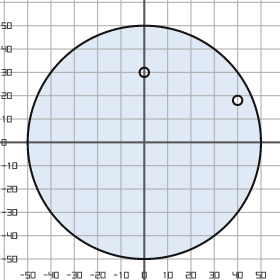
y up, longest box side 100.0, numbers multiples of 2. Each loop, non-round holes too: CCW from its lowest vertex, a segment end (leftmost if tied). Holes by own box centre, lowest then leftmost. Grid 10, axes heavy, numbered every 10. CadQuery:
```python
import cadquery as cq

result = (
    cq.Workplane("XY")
    .moveTo(0.0, 0.0)
    .circle(50.0)
    .moveTo(40.0, 18.0)
    .circle(2.0)
    .moveTo(0.0, 30.0)
    .circle(2.0)
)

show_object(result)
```